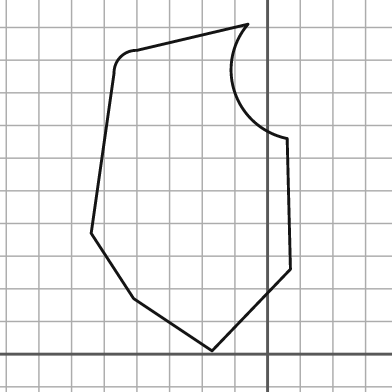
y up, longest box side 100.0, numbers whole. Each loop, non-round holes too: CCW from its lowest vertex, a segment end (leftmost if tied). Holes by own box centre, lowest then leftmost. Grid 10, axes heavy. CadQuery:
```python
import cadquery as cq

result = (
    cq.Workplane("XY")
    .moveTo(-17.0, 1.0)
    .lineTo(7.0, 26.0)
    .lineTo(6.0, 66.0)
    .threePointArc((-10.0, 80.0), (-6.0, 101.0))
    .lineTo(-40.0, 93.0)
    .threePointArc((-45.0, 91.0), (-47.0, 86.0))
    .lineTo(-54.0, 37.0)
    .lineTo(-41.0, 17.0)
    .close()
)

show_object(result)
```